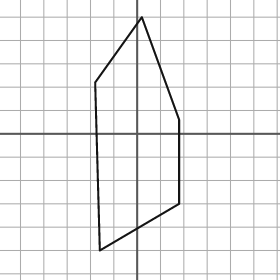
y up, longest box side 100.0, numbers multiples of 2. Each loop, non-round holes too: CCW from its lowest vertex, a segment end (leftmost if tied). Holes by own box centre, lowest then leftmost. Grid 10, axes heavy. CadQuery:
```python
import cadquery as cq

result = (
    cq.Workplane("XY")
    .moveTo(-16.0, -50.0)
    .lineTo(18.0, -30.0)
    .lineTo(18.0, 6.0)
    .lineTo(2.0, 50.0)
    .lineTo(-18.0, 22.0)
    .close()
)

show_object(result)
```